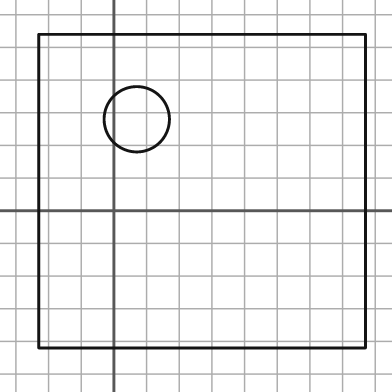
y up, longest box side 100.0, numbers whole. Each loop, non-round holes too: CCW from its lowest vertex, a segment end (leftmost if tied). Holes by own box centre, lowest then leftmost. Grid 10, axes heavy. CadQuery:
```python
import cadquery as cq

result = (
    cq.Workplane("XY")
    .moveTo(-23.0, -42.0)
    .lineTo(77.0, -42.0)
    .lineTo(77.0, 54.0)
    .lineTo(-23.0, 54.0)
    .close()
    .moveTo(7.0, 28.0)
    .circle(10.0)
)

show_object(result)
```